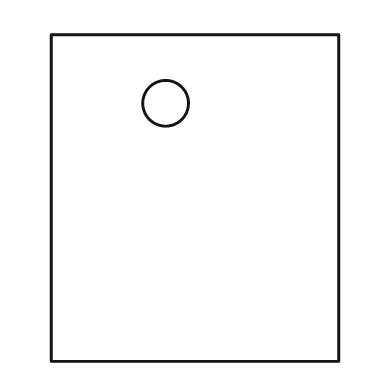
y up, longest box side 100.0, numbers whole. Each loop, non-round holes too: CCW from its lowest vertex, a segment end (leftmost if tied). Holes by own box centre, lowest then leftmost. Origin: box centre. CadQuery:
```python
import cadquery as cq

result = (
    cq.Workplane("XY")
    .moveTo(-44.0, -50.0)
    .lineTo(44.0, -50.0)
    .lineTo(44.0, 50.0)
    .lineTo(-44.0, 50.0)
    .close()
    .moveTo(-9.0, 29.0)
    .circle(7.0)
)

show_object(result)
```